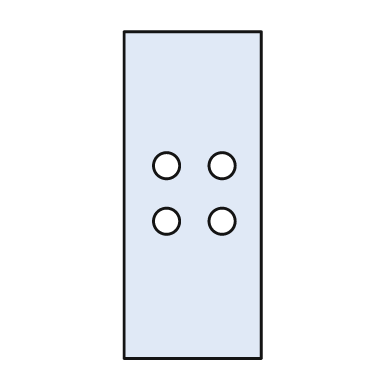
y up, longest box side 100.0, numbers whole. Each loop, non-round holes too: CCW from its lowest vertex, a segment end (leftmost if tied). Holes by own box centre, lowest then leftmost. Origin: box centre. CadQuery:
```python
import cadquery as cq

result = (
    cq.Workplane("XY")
    .moveTo(-21.0, -50.0)
    .lineTo(21.0, -50.0)
    .lineTo(21.0, 50.0)
    .lineTo(-21.0, 50.0)
    .close()
    .moveTo(-8.0, -8.0)
    .circle(4.0)
    .moveTo(9.0, -8.0)
    .circle(4.0)
    .moveTo(-8.0, 9.0)
    .circle(4.0)
    .moveTo(9.0, 9.0)
    .circle(4.0)
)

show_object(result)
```